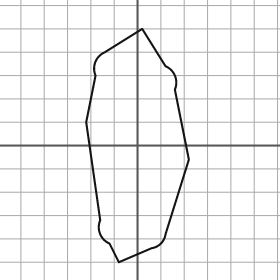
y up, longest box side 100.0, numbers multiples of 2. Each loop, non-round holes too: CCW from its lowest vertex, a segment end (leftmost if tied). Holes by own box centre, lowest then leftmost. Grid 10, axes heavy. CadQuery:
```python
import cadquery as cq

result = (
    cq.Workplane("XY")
    .moveTo(-8.0, -50.0)
    .lineTo(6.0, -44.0)
    .threePointArc((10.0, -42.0), (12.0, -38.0))
    .lineTo(22.0, -6.0)
    .lineTo(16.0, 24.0)
    .threePointArc((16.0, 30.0), (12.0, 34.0))
    .lineTo(2.0, 50.0)
    .lineTo(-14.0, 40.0)
    .threePointArc((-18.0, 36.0), (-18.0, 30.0))
    .lineTo(-22.0, 10.0)
    .lineTo(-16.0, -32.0)
    .threePointArc((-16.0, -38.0), (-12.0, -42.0))
    .close()
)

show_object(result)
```